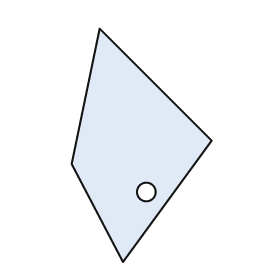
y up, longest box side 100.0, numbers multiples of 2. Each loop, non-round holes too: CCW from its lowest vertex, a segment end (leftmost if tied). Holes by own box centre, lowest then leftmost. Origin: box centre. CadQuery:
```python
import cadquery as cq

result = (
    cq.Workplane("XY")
    .moveTo(-8.0, -50.0)
    .lineTo(30.0, 2.0)
    .lineTo(-18.0, 50.0)
    .lineTo(-30.0, -8.0)
    .close()
    .moveTo(2.0, -20.0)
    .circle(4.0)
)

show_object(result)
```